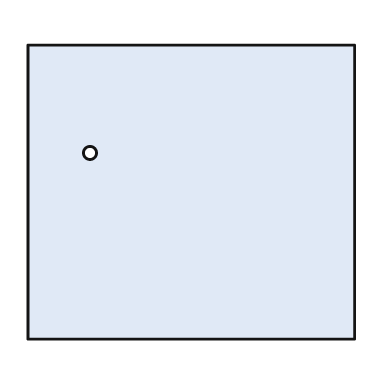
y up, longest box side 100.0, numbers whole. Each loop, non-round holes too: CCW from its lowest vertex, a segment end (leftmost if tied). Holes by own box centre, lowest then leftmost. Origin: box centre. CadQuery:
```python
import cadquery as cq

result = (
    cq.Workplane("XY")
    .moveTo(-50.0, -45.0)
    .lineTo(50.0, -45.0)
    .lineTo(50.0, 45.0)
    .lineTo(-50.0, 45.0)
    .close()
    .moveTo(-31.0, 12.0)
    .circle(2.0)
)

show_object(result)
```